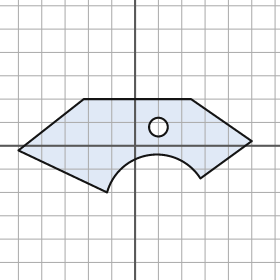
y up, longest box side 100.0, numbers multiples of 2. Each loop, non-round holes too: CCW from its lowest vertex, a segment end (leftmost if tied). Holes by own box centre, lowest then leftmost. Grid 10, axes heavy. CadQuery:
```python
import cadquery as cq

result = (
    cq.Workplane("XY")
    .moveTo(-12.0, -20.0)
    .threePointArc((6.0, -4.0), (28.0, -14.0))
    .lineTo(50.0, 2.0)
    .lineTo(24.0, 20.0)
    .lineTo(-22.0, 20.0)
    .lineTo(-50.0, -2.0)
    .close()
    .moveTo(10.0, 8.0)
    .circle(4.0)
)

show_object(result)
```